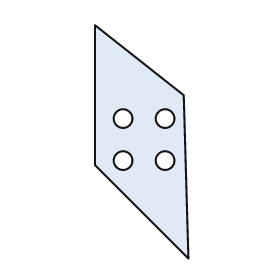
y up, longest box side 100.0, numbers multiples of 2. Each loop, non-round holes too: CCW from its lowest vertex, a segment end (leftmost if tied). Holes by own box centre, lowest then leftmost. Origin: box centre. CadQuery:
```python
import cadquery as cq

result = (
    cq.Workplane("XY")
    .moveTo(20.0, -50.0)
    .lineTo(18.0, 20.0)
    .lineTo(-20.0, 50.0)
    .lineTo(-20.0, -10.0)
    .close()
    .moveTo(-8.0, -8.0)
    .circle(4.0)
    .moveTo(10.0, -8.0)
    .circle(4.0)
    .moveTo(-8.0, 10.0)
    .circle(4.0)
    .moveTo(10.0, 10.0)
    .circle(4.0)
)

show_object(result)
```